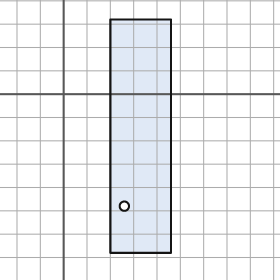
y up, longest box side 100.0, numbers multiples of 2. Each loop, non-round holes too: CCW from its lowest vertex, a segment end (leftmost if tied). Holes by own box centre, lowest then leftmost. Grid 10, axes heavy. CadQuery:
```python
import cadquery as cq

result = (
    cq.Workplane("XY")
    .moveTo(20.0, -68.0)
    .lineTo(46.0, -68.0)
    .lineTo(46.0, 32.0)
    .lineTo(20.0, 32.0)
    .close()
    .moveTo(26.0, -48.0)
    .circle(2.0)
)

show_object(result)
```